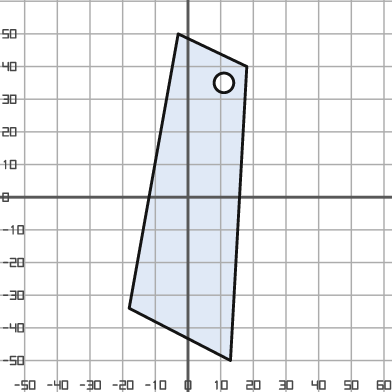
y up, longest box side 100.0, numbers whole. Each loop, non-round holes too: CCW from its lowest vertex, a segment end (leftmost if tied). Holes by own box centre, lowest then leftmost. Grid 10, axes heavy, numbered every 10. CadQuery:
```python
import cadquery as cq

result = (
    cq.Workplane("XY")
    .moveTo(13.0, -50.0)
    .lineTo(18.0, 40.0)
    .lineTo(-3.0, 50.0)
    .lineTo(-18.0, -34.0)
    .close()
    .moveTo(11.0, 35.0)
    .circle(3.0)
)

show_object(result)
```